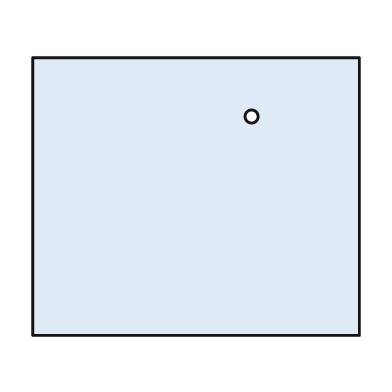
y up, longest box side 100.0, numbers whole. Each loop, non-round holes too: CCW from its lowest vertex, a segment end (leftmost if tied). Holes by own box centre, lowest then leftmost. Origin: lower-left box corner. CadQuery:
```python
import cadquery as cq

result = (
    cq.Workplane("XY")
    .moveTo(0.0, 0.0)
    .lineTo(100.0, 0.0)
    .lineTo(100.0, 85.0)
    .lineTo(0.0, 85.0)
    .close()
    .moveTo(67.0, 67.0)
    .circle(2.0)
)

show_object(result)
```